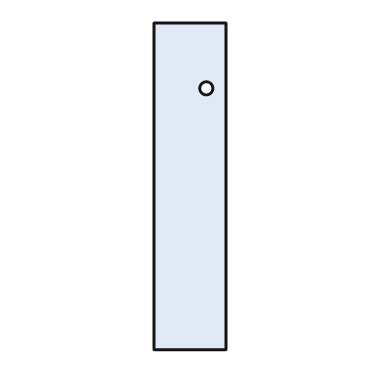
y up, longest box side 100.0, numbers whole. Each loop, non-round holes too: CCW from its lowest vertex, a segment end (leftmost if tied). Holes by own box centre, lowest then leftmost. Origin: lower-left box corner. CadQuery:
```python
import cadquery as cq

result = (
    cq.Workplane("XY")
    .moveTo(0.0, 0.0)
    .lineTo(22.0, 0.0)
    .lineTo(22.0, 100.0)
    .lineTo(0.0, 100.0)
    .close()
    .moveTo(16.0, 80.0)
    .circle(2.0)
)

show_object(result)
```